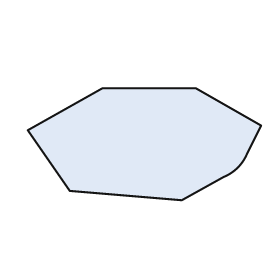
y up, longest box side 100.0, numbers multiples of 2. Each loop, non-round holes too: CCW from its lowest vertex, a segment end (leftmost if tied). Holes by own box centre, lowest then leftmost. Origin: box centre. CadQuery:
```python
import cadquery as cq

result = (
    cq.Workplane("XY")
    .moveTo(16.0, -24.0)
    .lineTo(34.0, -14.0)
    .threePointArc((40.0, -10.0), (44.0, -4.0))
    .lineTo(50.0, 8.0)
    .lineTo(22.0, 24.0)
    .lineTo(-18.0, 24.0)
    .lineTo(-50.0, 6.0)
    .lineTo(-32.0, -20.0)
    .close()
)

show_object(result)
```